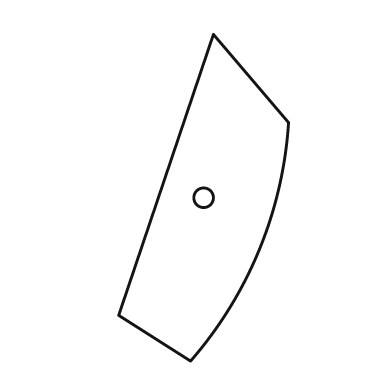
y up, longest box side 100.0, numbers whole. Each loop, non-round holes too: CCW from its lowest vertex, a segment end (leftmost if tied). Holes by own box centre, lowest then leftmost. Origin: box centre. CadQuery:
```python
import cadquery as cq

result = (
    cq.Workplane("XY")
    .moveTo(-4.0, -50.0)
    .threePointArc((17.0, -16.0), (26.0, 23.0))
    .lineTo(3.0, 50.0)
    .lineTo(-26.0, -36.0)
    .close()
    .moveTo(0.0, 0.0)
    .circle(3.0)
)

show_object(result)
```